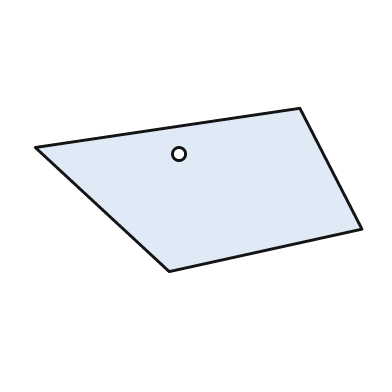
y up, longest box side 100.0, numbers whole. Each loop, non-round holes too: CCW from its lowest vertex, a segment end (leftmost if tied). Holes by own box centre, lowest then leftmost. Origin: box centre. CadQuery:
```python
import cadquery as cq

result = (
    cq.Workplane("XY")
    .moveTo(-9.0, -25.0)
    .lineTo(50.0, -12.0)
    .lineTo(31.0, 25.0)
    .lineTo(-50.0, 13.0)
    .close()
    .moveTo(-6.0, 11.0)
    .circle(2.0)
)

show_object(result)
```